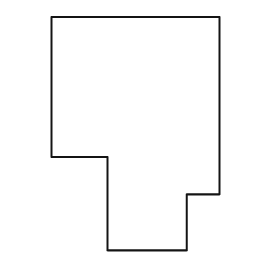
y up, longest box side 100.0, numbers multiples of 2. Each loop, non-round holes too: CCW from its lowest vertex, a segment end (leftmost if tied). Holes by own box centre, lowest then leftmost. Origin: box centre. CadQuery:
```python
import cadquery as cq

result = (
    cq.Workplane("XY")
    .moveTo(-12.0, -50.0)
    .lineTo(22.0, -50.0)
    .lineTo(22.0, -26.0)
    .lineTo(36.0, -26.0)
    .lineTo(36.0, 50.0)
    .lineTo(-36.0, 50.0)
    .lineTo(-36.0, -10.0)
    .lineTo(-12.0, -10.0)
    .close()
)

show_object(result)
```